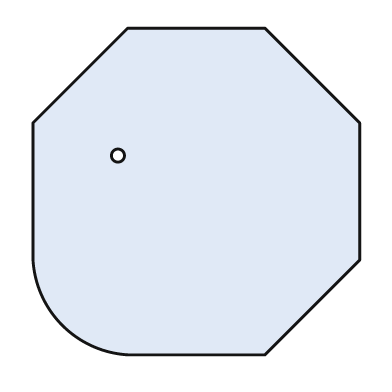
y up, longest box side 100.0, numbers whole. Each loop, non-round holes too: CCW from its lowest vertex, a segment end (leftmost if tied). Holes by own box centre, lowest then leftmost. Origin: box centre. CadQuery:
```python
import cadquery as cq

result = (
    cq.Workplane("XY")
    .moveTo(-21.0, -50.0)
    .lineTo(21.0, -50.0)
    .lineTo(50.0, -21.0)
    .lineTo(50.0, 21.0)
    .lineTo(21.0, 50.0)
    .lineTo(-21.0, 50.0)
    .lineTo(-50.0, 21.0)
    .lineTo(-50.0, -21.0)
    .threePointArc((-41.0, -41.0), (-21.0, -50.0))
    .close()
    .moveTo(-24.0, 11.0)
    .circle(2.0)
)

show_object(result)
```